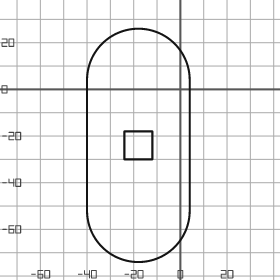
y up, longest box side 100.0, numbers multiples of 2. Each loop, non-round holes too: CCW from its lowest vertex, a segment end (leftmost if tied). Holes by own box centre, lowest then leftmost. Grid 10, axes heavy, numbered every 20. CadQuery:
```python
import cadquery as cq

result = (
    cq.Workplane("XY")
    .moveTo(-40.0, -52.0)
    .threePointArc((-18.0, -74.0), (4.0, -52.0))
    .lineTo(4.0, 4.0)
    .threePointArc((-18.0, 26.0), (-40.0, 4.0))
    .close()
    .moveTo(-24.0, -30.0)
    .lineTo(-12.0, -30.0)
    .lineTo(-12.0, -18.0)
    .lineTo(-24.0, -18.0)
    .close()
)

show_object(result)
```